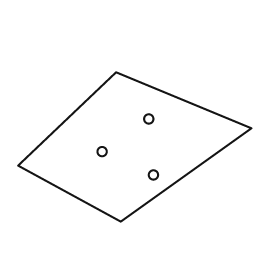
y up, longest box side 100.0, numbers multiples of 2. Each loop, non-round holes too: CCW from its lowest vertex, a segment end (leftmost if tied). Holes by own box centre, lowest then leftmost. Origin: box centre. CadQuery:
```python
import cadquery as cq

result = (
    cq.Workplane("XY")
    .moveTo(-6.0, -32.0)
    .lineTo(50.0, 8.0)
    .lineTo(-8.0, 32.0)
    .lineTo(-50.0, -8.0)
    .close()
    .moveTo(8.0, -12.0)
    .circle(2.0)
    .moveTo(-14.0, -2.0)
    .circle(2.0)
    .moveTo(6.0, 12.0)
    .circle(2.0)
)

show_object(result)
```